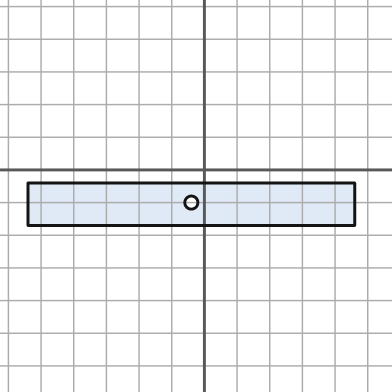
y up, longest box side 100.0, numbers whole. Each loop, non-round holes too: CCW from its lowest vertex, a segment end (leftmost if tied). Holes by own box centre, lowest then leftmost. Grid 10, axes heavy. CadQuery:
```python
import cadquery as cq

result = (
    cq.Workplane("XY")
    .moveTo(-54.0, -17.0)
    .lineTo(46.0, -17.0)
    .lineTo(46.0, -4.0)
    .lineTo(-54.0, -4.0)
    .close()
    .moveTo(-4.0, -10.0)
    .circle(2.0)
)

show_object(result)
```